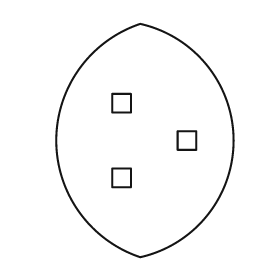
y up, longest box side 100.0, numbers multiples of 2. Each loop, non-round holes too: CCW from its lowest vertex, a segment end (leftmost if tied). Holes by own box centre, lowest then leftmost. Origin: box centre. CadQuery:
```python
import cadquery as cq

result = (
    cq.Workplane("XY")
    .moveTo(-2.0, -50.0)
    .threePointArc((38.0, 0.0), (-2.0, 50.0))
    .threePointArc((-38.0, 0.0), (-2.0, -50.0))
    .close()
    .moveTo(-14.0, -20.0)
    .lineTo(-6.0, -20.0)
    .lineTo(-6.0, -12.0)
    .lineTo(-14.0, -12.0)
    .close()
    .moveTo(14.0, -4.0)
    .lineTo(22.0, -4.0)
    .lineTo(22.0, 4.0)
    .lineTo(14.0, 4.0)
    .close()
    .moveTo(-14.0, 12.0)
    .lineTo(-6.0, 12.0)
    .lineTo(-6.0, 20.0)
    .lineTo(-14.0, 20.0)
    .close()
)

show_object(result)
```